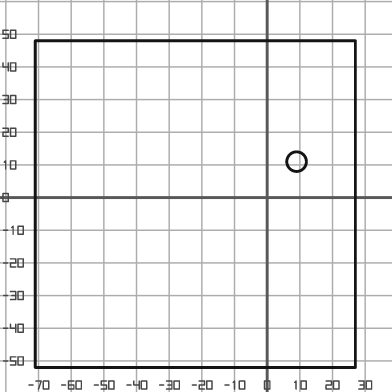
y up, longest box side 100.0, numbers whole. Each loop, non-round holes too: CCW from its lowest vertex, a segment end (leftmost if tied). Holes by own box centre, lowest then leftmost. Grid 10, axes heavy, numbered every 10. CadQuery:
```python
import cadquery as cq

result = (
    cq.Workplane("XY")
    .moveTo(-71.0, -52.0)
    .lineTo(27.0, -52.0)
    .lineTo(27.0, 48.0)
    .lineTo(-71.0, 48.0)
    .close()
    .moveTo(9.0, 11.0)
    .circle(3.0)
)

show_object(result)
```